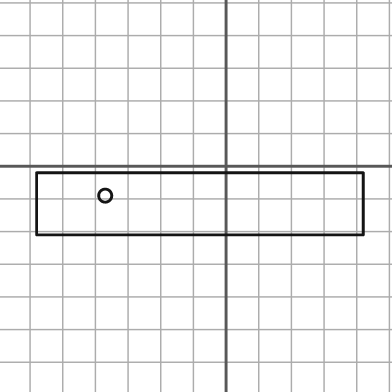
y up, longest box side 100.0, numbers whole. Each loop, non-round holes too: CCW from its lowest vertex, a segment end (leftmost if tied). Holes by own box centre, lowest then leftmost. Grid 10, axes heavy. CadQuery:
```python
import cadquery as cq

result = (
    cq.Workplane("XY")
    .moveTo(-58.0, -21.0)
    .lineTo(42.0, -21.0)
    .lineTo(42.0, -2.0)
    .lineTo(-58.0, -2.0)
    .close()
    .moveTo(-37.0, -9.0)
    .circle(2.0)
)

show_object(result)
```